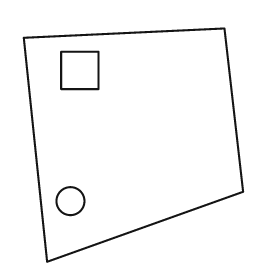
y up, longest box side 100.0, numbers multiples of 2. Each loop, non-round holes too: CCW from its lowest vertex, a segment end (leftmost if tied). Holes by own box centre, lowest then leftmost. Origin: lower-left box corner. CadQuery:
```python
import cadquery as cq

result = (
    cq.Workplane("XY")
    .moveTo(10.0, 0.0)
    .lineTo(94.0, 30.0)
    .lineTo(86.0, 100.0)
    .lineTo(0.0, 96.0)
    .close()
    .moveTo(20.0, 26.0)
    .circle(6.0)
    .moveTo(16.0, 74.0)
    .lineTo(32.0, 74.0)
    .lineTo(32.0, 90.0)
    .lineTo(16.0, 90.0)
    .close()
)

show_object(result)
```